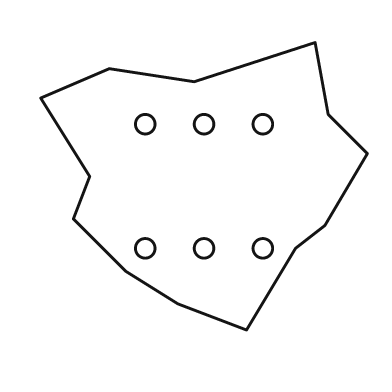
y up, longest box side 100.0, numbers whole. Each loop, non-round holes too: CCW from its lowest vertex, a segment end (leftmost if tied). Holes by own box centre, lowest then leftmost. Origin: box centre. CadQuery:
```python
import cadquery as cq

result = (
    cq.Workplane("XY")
    .moveTo(13.0, -44.0)
    .lineTo(28.0, -19.0)
    .lineTo(37.0, -12.0)
    .lineTo(50.0, 10.0)
    .lineTo(38.0, 22.0)
    .lineTo(34.0, 44.0)
    .lineTo(-3.0, 32.0)
    .lineTo(-29.0, 36.0)
    .lineTo(-50.0, 27.0)
    .lineTo(-35.0, 3.0)
    .lineTo(-40.0, -10.0)
    .lineTo(-24.0, -26.0)
    .lineTo(-8.0, -36.0)
    .close()
    .moveTo(-18.0, -19.0)
    .circle(3.0)
    .moveTo(0.0, -19.0)
    .circle(3.0)
    .moveTo(18.0, -19.0)
    .circle(3.0)
    .moveTo(-18.0, 19.0)
    .circle(3.0)
    .moveTo(0.0, 19.0)
    .circle(3.0)
    .moveTo(18.0, 19.0)
    .circle(3.0)
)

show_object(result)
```